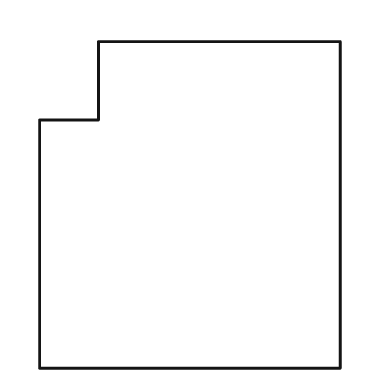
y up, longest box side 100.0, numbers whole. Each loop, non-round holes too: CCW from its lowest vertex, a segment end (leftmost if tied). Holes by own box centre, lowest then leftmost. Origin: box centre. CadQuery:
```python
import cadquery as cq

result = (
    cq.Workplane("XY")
    .moveTo(-46.0, -50.0)
    .lineTo(46.0, -50.0)
    .lineTo(46.0, 50.0)
    .lineTo(-28.0, 50.0)
    .lineTo(-28.0, 26.0)
    .lineTo(-46.0, 26.0)
    .close()
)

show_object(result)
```